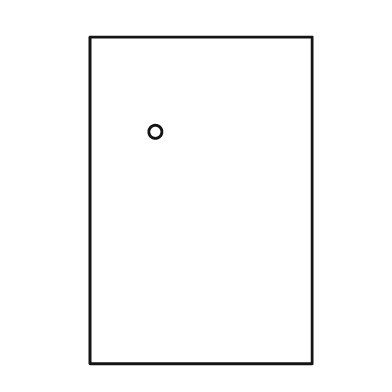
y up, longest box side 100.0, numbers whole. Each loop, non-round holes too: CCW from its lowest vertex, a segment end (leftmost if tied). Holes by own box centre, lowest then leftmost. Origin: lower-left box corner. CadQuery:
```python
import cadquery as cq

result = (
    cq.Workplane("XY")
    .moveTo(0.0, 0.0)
    .lineTo(68.0, 0.0)
    .lineTo(68.0, 100.0)
    .lineTo(0.0, 100.0)
    .close()
    .moveTo(20.0, 71.0)
    .circle(2.0)
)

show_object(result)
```